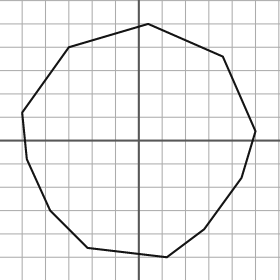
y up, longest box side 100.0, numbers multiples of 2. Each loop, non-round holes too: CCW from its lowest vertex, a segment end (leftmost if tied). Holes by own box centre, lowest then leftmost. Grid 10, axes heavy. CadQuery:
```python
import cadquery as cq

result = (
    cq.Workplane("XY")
    .moveTo(12.0, -50.0)
    .lineTo(28.0, -38.0)
    .lineTo(44.0, -16.0)
    .lineTo(50.0, 4.0)
    .lineTo(36.0, 36.0)
    .lineTo(4.0, 50.0)
    .lineTo(-30.0, 40.0)
    .lineTo(-50.0, 12.0)
    .lineTo(-48.0, -8.0)
    .lineTo(-38.0, -30.0)
    .lineTo(-22.0, -46.0)
    .close()
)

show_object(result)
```